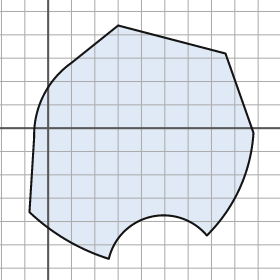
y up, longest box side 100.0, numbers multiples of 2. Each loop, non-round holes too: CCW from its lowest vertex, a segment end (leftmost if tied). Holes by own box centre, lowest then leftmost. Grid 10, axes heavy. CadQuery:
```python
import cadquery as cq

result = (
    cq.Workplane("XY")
    .moveTo(26.0, -56.0)
    .threePointArc((44.0, -38.0), (68.0, -46.0))
    .threePointArc((82.0, -26.0), (88.0, -2.0))
    .lineTo(76.0, 32.0)
    .lineTo(30.0, 44.0)
    .lineTo(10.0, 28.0)
    .threePointArc((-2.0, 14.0), (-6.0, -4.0))
    .lineTo(-8.0, -36.0)
    .threePointArc((8.0, -48.0), (26.0, -56.0))
    .close()
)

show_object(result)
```